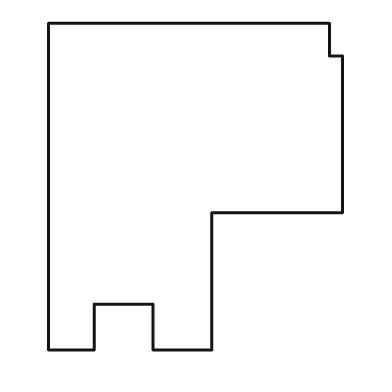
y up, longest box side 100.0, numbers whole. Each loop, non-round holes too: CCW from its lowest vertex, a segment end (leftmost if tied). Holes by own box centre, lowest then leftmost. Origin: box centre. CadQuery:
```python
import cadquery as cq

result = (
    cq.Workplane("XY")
    .moveTo(-45.0, -50.0)
    .lineTo(-31.0, -50.0)
    .lineTo(-31.0, -36.0)
    .lineTo(-13.0, -36.0)
    .lineTo(-13.0, -50.0)
    .lineTo(5.0, -50.0)
    .lineTo(5.0, -8.0)
    .lineTo(45.0, -8.0)
    .lineTo(45.0, 40.0)
    .lineTo(41.0, 40.0)
    .lineTo(41.0, 50.0)
    .lineTo(-45.0, 50.0)
    .close()
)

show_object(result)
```